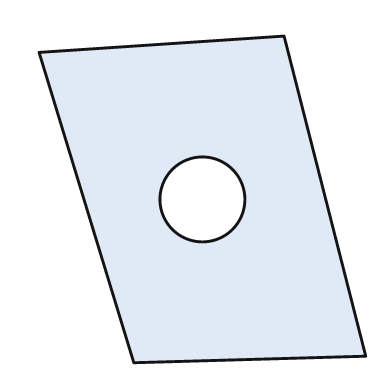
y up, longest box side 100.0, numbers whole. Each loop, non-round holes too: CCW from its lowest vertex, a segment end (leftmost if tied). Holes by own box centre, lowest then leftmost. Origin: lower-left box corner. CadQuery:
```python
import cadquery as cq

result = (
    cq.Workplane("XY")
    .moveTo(29.0, 0.0)
    .lineTo(100.0, 2.0)
    .lineTo(75.0, 100.0)
    .lineTo(0.0, 95.0)
    .close()
    .moveTo(50.0, 50.0)
    .circle(13.0)
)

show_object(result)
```